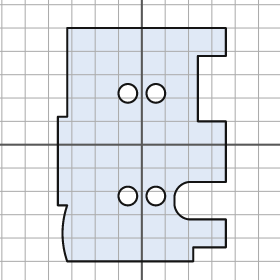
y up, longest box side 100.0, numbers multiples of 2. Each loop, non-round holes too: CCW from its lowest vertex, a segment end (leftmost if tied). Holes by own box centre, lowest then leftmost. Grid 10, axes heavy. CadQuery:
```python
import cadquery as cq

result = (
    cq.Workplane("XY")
    .moveTo(-32.0, -50.0)
    .lineTo(22.0, -50.0)
    .lineTo(22.0, -44.0)
    .lineTo(36.0, -44.0)
    .lineTo(36.0, -32.0)
    .lineTo(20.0, -32.0)
    .threePointArc((16.0, -30.0), (14.0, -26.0))
    .lineTo(14.0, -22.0)
    .threePointArc((16.0, -18.0), (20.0, -16.0))
    .lineTo(36.0, -16.0)
    .lineTo(36.0, 10.0)
    .lineTo(24.0, 10.0)
    .lineTo(24.0, 38.0)
    .lineTo(36.0, 38.0)
    .lineTo(36.0, 50.0)
    .lineTo(-32.0, 50.0)
    .lineTo(-32.0, 12.0)
    .lineTo(-36.0, 12.0)
    .lineTo(-36.0, -26.0)
    .lineTo(-32.0, -26.0)
    .threePointArc((-34.0, -38.0), (-32.0, -50.0))
    .close()
    .moveTo(-6.0, -22.0)
    .circle(4.0)
    .moveTo(6.0, -22.0)
    .circle(4.0)
    .moveTo(-6.0, 22.0)
    .circle(4.0)
    .moveTo(6.0, 22.0)
    .circle(4.0)
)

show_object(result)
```